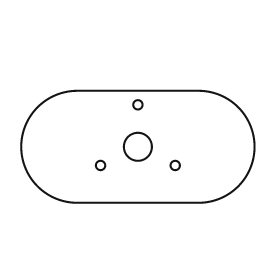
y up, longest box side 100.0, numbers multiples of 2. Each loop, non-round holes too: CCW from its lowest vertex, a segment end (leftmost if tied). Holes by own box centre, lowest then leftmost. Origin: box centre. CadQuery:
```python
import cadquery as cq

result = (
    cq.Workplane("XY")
    .moveTo(-26.0, -24.0)
    .lineTo(26.0, -24.0)
    .threePointArc((50.0, 0.0), (26.0, 24.0))
    .lineTo(-26.0, 24.0)
    .threePointArc((-50.0, 0.0), (-26.0, -24.0))
    .close()
    .moveTo(-16.0, -8.0)
    .circle(2.0)
    .moveTo(16.0, -8.0)
    .circle(2.0)
    .moveTo(0.0, 0.0)
    .circle(6.0)
    .moveTo(0.0, 18.0)
    .circle(2.0)
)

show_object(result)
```